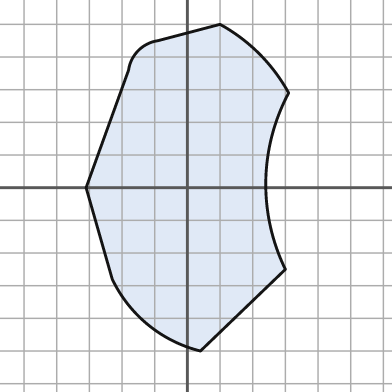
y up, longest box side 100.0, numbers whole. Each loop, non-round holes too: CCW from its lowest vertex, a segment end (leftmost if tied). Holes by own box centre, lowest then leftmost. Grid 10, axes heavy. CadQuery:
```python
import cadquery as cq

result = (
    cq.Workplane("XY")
    .moveTo(4.0, -50.0)
    .lineTo(30.0, -25.0)
    .threePointArc((24.0, 2.0), (31.0, 29.0))
    .threePointArc((22.0, 41.0), (10.0, 50.0))
    .lineTo(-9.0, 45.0)
    .threePointArc((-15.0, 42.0), (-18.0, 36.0))
    .lineTo(-31.0, 0.0)
    .lineTo(-23.0, -28.0)
    .threePointArc((-12.0, -42.0), (4.0, -50.0))
    .close()
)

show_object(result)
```